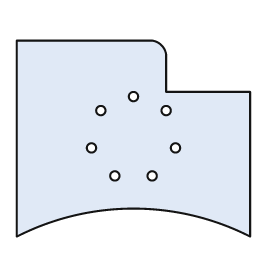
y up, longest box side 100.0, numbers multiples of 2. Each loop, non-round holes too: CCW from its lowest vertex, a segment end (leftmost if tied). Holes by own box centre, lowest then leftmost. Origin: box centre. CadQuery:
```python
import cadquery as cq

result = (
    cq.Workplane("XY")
    .moveTo(-50.0, -42.0)
    .threePointArc((0.0, -30.0), (50.0, -42.0))
    .lineTo(50.0, 20.0)
    .lineTo(14.0, 20.0)
    .lineTo(14.0, 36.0)
    .threePointArc((12.0, 40.0), (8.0, 42.0))
    .lineTo(-50.0, 42.0)
    .close()
    .moveTo(-8.0, -16.0)
    .circle(2.0)
    .moveTo(8.0, -16.0)
    .circle(2.0)
    .moveTo(-18.0, -4.0)
    .circle(2.0)
    .moveTo(18.0, -4.0)
    .circle(2.0)
    .moveTo(-14.0, 12.0)
    .circle(2.0)
    .moveTo(14.0, 12.0)
    .circle(2.0)
    .moveTo(0.0, 18.0)
    .circle(2.0)
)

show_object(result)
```